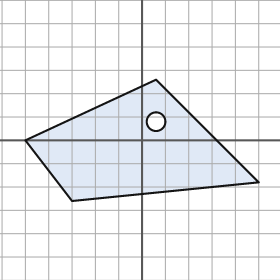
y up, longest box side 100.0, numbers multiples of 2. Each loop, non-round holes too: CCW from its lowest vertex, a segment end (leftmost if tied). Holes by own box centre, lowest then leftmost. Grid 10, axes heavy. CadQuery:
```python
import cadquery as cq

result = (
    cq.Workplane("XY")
    .moveTo(-30.0, -26.0)
    .lineTo(50.0, -18.0)
    .lineTo(6.0, 26.0)
    .lineTo(-50.0, 0.0)
    .close()
    .moveTo(6.0, 8.0)
    .circle(4.0)
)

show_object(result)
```